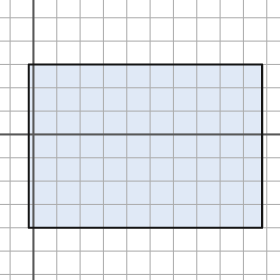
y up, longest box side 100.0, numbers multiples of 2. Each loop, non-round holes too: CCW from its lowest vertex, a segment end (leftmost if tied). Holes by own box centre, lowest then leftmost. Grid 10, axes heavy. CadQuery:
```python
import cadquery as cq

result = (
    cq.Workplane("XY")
    .moveTo(-2.0, -40.0)
    .lineTo(98.0, -40.0)
    .lineTo(98.0, 30.0)
    .lineTo(-2.0, 30.0)
    .close()
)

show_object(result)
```